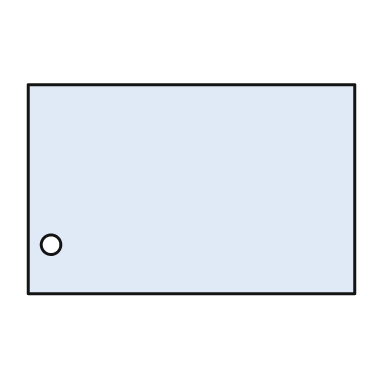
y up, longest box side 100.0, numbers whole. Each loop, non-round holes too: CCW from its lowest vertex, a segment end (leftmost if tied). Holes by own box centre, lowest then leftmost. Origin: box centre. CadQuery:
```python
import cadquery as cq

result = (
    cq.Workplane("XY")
    .moveTo(-50.0, -32.0)
    .lineTo(50.0, -32.0)
    .lineTo(50.0, 32.0)
    .lineTo(-50.0, 32.0)
    .close()
    .moveTo(-43.0, -17.0)
    .circle(3.0)
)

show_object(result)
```